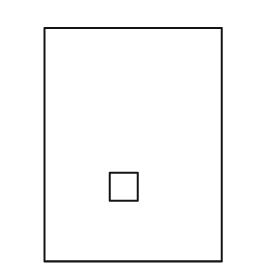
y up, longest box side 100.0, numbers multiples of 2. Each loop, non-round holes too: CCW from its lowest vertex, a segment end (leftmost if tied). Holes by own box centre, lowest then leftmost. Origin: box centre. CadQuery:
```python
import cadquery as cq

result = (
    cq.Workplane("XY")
    .moveTo(-38.0, -50.0)
    .lineTo(38.0, -50.0)
    .lineTo(38.0, 50.0)
    .lineTo(-38.0, 50.0)
    .close()
    .moveTo(-10.0, -24.0)
    .lineTo(2.0, -24.0)
    .lineTo(2.0, -12.0)
    .lineTo(-10.0, -12.0)
    .close()
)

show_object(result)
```